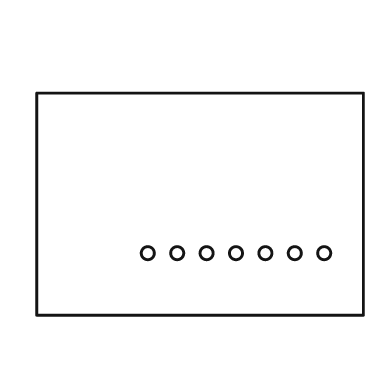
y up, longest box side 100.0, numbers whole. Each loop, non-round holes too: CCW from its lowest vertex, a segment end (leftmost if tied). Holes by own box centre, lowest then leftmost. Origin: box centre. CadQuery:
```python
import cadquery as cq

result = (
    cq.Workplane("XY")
    .moveTo(-50.0, -34.0)
    .lineTo(50.0, -34.0)
    .lineTo(50.0, 34.0)
    .lineTo(-50.0, 34.0)
    .close()
    .moveTo(-16.0, -15.0)
    .circle(2.0)
    .moveTo(-7.0, -15.0)
    .circle(2.0)
    .moveTo(2.0, -15.0)
    .circle(2.0)
    .moveTo(11.0, -15.0)
    .circle(2.0)
    .moveTo(20.0, -15.0)
    .circle(2.0)
    .moveTo(29.0, -15.0)
    .circle(2.0)
    .moveTo(38.0, -15.0)
    .circle(2.0)
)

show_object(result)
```